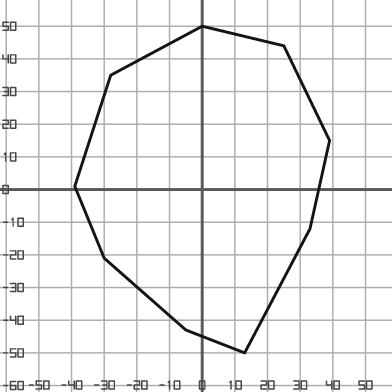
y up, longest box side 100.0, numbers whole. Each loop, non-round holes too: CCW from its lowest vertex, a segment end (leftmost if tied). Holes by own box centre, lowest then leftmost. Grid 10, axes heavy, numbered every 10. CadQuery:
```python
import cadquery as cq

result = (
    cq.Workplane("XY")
    .moveTo(13.0, -50.0)
    .lineTo(33.0, -12.0)
    .lineTo(39.0, 15.0)
    .lineTo(25.0, 44.0)
    .lineTo(0.0, 50.0)
    .lineTo(-28.0, 35.0)
    .lineTo(-39.0, 1.0)
    .lineTo(-30.0, -21.0)
    .lineTo(-5.0, -43.0)
    .close()
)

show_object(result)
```